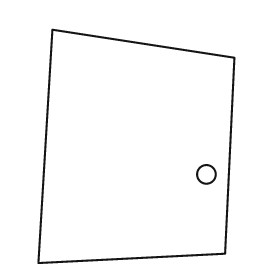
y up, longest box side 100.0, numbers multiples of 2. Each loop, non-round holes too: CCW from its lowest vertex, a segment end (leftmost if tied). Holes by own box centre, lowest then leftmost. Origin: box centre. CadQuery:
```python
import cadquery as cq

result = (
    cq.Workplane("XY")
    .moveTo(-42.0, -50.0)
    .lineTo(38.0, -46.0)
    .lineTo(42.0, 38.0)
    .lineTo(-36.0, 50.0)
    .close()
    .moveTo(30.0, -12.0)
    .circle(4.0)
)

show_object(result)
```